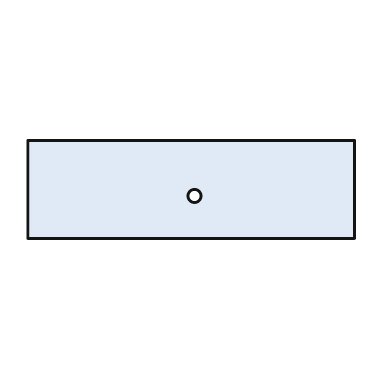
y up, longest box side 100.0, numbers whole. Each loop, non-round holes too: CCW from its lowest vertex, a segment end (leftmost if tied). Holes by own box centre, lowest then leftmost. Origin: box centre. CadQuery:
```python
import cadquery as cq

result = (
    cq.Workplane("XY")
    .moveTo(-50.0, -15.0)
    .lineTo(50.0, -15.0)
    .lineTo(50.0, 15.0)
    .lineTo(-50.0, 15.0)
    .close()
    .moveTo(1.0, -2.0)
    .circle(2.0)
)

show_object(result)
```